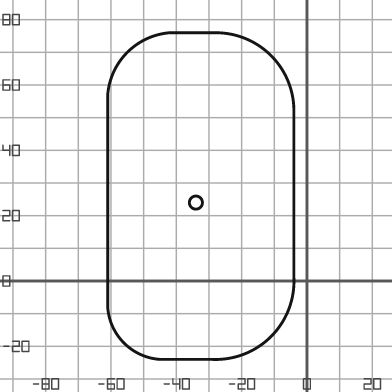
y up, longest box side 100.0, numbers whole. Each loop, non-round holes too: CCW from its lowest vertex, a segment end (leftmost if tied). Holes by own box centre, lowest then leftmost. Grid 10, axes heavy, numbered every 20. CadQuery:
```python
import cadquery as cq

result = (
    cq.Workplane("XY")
    .moveTo(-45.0, -24.0)
    .lineTo(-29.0, -24.0)
    .threePointArc((-11.0, -17.0), (-4.0, 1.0))
    .lineTo(-4.0, 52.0)
    .threePointArc((-11.0, 69.0), (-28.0, 76.0))
    .lineTo(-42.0, 76.0)
    .threePointArc((-55.0, 70.0), (-61.0, 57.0))
    .lineTo(-61.0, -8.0)
    .threePointArc((-56.0, -19.0), (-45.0, -24.0))
    .close()
    .moveTo(-34.0, 24.0)
    .circle(2.0)
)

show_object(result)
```